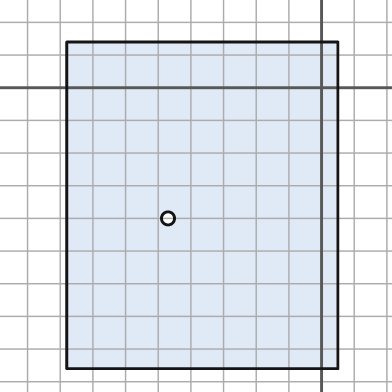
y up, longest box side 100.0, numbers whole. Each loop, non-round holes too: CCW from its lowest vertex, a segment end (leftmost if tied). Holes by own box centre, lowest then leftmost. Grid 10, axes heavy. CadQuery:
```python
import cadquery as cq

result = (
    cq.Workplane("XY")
    .moveTo(-78.0, -86.0)
    .lineTo(5.0, -86.0)
    .lineTo(5.0, 14.0)
    .lineTo(-78.0, 14.0)
    .close()
    .moveTo(-47.0, -40.0)
    .circle(2.0)
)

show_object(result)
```